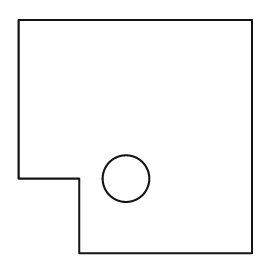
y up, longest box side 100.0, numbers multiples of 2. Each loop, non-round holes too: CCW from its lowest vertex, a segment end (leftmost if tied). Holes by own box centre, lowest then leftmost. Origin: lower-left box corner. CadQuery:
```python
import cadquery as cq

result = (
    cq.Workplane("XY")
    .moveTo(26.0, 0.0)
    .lineTo(100.0, 0.0)
    .lineTo(100.0, 100.0)
    .lineTo(0.0, 100.0)
    .lineTo(0.0, 32.0)
    .lineTo(26.0, 32.0)
    .close()
    .moveTo(46.0, 32.0)
    .circle(10.0)
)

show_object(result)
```